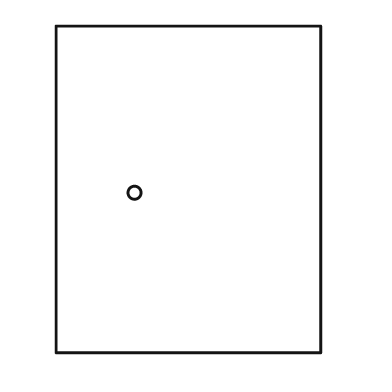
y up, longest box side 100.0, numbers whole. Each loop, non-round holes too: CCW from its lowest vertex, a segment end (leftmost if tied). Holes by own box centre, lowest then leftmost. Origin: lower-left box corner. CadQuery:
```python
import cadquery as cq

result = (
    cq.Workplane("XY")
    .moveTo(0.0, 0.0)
    .lineTo(81.0, 0.0)
    .lineTo(81.0, 100.0)
    .lineTo(0.0, 100.0)
    .close()
    .moveTo(24.0, 49.0)
    .circle(2.0)
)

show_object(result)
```